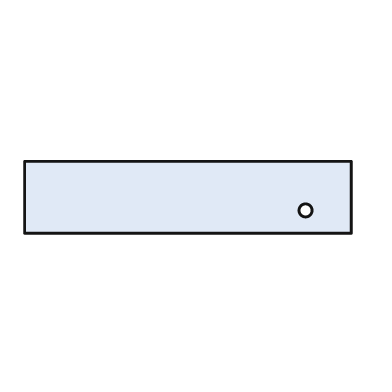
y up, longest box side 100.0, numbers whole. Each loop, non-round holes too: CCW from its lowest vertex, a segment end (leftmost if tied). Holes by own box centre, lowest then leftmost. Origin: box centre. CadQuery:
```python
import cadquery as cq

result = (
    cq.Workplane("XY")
    .moveTo(-50.0, -11.0)
    .lineTo(50.0, -11.0)
    .lineTo(50.0, 11.0)
    .lineTo(-50.0, 11.0)
    .close()
    .moveTo(36.0, -4.0)
    .circle(2.0)
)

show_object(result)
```